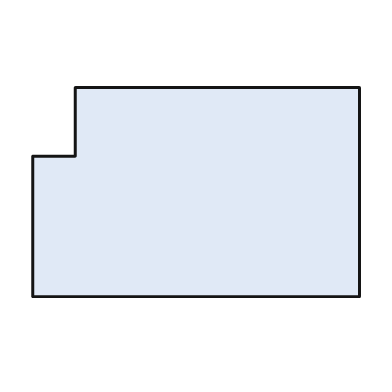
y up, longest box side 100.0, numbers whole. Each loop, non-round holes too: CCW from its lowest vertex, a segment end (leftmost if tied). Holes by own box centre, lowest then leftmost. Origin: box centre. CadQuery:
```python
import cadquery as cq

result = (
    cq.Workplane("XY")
    .moveTo(-50.0, -32.0)
    .lineTo(50.0, -32.0)
    .lineTo(50.0, 32.0)
    .lineTo(-37.0, 32.0)
    .lineTo(-37.0, 11.0)
    .lineTo(-50.0, 11.0)
    .close()
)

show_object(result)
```